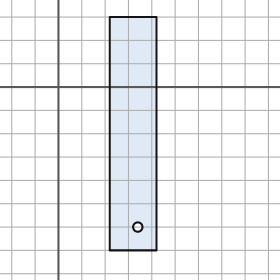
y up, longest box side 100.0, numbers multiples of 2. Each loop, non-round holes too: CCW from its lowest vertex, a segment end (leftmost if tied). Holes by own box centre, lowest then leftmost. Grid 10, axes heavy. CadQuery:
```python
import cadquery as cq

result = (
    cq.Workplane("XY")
    .moveTo(22.0, -70.0)
    .lineTo(42.0, -70.0)
    .lineTo(42.0, 30.0)
    .lineTo(22.0, 30.0)
    .close()
    .moveTo(34.0, -60.0)
    .circle(2.0)
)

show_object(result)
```